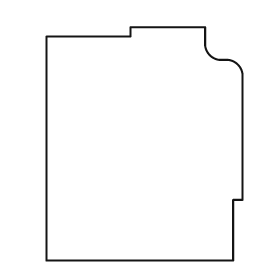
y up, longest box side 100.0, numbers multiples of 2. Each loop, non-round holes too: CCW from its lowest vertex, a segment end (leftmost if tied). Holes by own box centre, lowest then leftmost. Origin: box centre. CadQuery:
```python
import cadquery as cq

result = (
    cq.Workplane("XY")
    .moveTo(-42.0, -50.0)
    .lineTo(38.0, -50.0)
    .lineTo(38.0, -24.0)
    .lineTo(42.0, -24.0)
    .lineTo(42.0, 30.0)
    .threePointArc((40.0, 34.0), (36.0, 36.0))
    .lineTo(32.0, 36.0)
    .threePointArc((28.0, 38.0), (26.0, 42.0))
    .lineTo(26.0, 50.0)
    .lineTo(-6.0, 50.0)
    .lineTo(-6.0, 46.0)
    .lineTo(-42.0, 46.0)
    .close()
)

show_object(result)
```